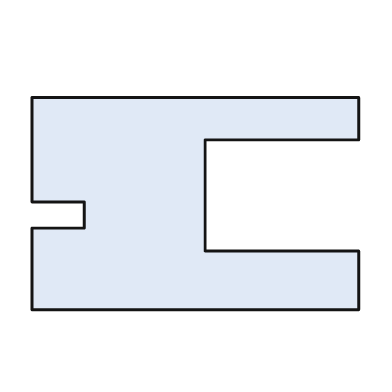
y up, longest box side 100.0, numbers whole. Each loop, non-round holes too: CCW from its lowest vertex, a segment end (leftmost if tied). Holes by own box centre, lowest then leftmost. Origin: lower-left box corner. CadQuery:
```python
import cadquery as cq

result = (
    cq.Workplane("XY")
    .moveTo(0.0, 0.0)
    .lineTo(100.0, 0.0)
    .lineTo(100.0, 18.0)
    .lineTo(53.0, 18.0)
    .lineTo(53.0, 52.0)
    .lineTo(100.0, 52.0)
    .lineTo(100.0, 65.0)
    .lineTo(0.0, 65.0)
    .lineTo(0.0, 33.0)
    .lineTo(16.0, 33.0)
    .lineTo(16.0, 25.0)
    .lineTo(0.0, 25.0)
    .close()
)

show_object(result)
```